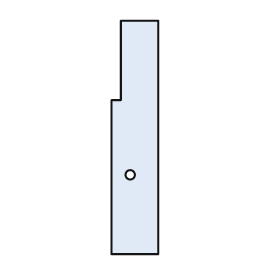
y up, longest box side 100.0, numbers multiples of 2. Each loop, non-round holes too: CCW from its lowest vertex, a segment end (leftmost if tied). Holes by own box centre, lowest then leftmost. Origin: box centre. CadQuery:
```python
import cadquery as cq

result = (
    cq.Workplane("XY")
    .moveTo(-10.0, -50.0)
    .lineTo(10.0, -50.0)
    .lineTo(10.0, 50.0)
    .lineTo(-6.0, 50.0)
    .lineTo(-6.0, 16.0)
    .lineTo(-10.0, 16.0)
    .close()
    .moveTo(-2.0, -16.0)
    .circle(2.0)
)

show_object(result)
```